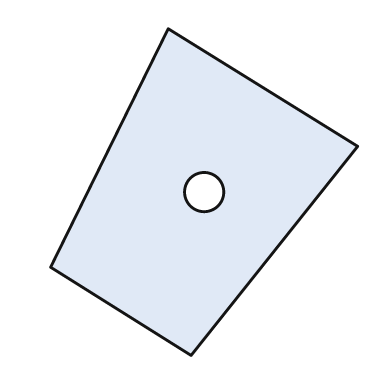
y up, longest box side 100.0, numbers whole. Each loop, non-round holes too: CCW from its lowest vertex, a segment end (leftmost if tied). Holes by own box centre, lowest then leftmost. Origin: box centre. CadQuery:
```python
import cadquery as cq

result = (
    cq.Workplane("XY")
    .moveTo(-4.0, -50.0)
    .lineTo(47.0, 14.0)
    .lineTo(-11.0, 50.0)
    .lineTo(-47.0, -23.0)
    .close()
    .moveTo(0.0, 0.0)
    .circle(6.0)
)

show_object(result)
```